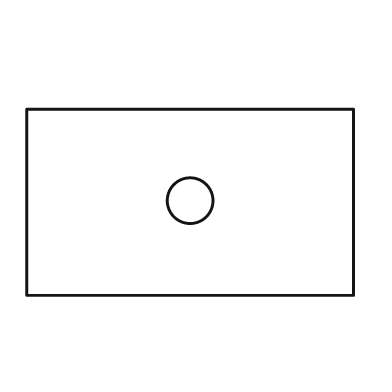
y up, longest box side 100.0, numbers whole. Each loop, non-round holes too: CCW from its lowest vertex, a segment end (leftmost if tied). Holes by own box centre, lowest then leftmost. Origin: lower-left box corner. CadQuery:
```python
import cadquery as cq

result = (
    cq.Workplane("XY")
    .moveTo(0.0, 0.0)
    .lineTo(100.0, 0.0)
    .lineTo(100.0, 57.0)
    .lineTo(0.0, 57.0)
    .close()
    .moveTo(50.0, 29.0)
    .circle(7.0)
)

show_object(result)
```